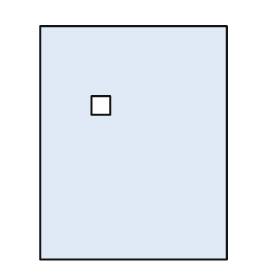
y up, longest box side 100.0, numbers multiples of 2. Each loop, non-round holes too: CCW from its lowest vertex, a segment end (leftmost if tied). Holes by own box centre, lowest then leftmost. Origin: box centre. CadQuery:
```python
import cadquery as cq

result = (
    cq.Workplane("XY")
    .moveTo(-40.0, -50.0)
    .lineTo(40.0, -50.0)
    .lineTo(40.0, 50.0)
    .lineTo(-40.0, 50.0)
    .close()
    .moveTo(-18.0, 12.0)
    .lineTo(-10.0, 12.0)
    .lineTo(-10.0, 20.0)
    .lineTo(-18.0, 20.0)
    .close()
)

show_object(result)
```